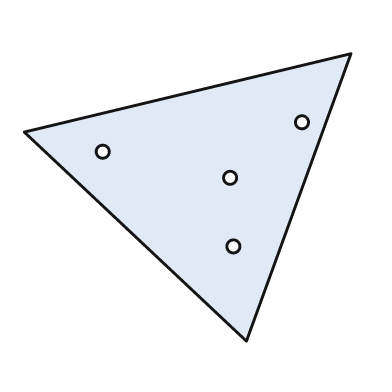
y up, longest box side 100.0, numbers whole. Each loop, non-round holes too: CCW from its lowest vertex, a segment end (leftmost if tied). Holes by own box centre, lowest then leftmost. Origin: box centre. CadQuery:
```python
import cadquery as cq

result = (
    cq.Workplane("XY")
    .moveTo(18.0, -44.0)
    .lineTo(50.0, 44.0)
    .lineTo(-50.0, 20.0)
    .close()
    .moveTo(14.0, -15.0)
    .circle(2.0)
    .moveTo(13.0, 6.0)
    .circle(2.0)
    .moveTo(-26.0, 14.0)
    .circle(2.0)
    .moveTo(35.0, 23.0)
    .circle(2.0)
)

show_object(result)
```